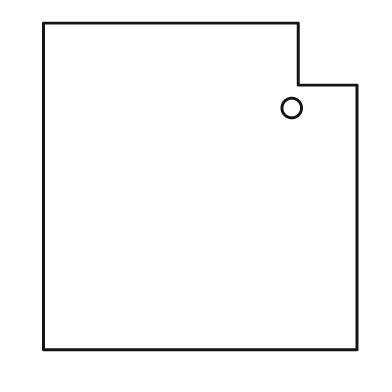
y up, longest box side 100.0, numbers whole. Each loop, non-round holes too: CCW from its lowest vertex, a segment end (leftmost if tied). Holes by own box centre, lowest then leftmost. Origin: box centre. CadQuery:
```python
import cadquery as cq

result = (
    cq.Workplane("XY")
    .moveTo(-48.0, -50.0)
    .lineTo(48.0, -50.0)
    .lineTo(48.0, 31.0)
    .lineTo(30.0, 31.0)
    .lineTo(30.0, 50.0)
    .lineTo(-48.0, 50.0)
    .close()
    .moveTo(28.0, 24.0)
    .circle(3.0)
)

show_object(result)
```